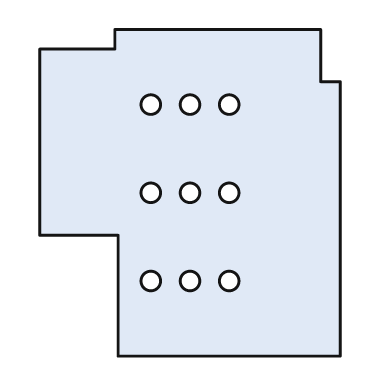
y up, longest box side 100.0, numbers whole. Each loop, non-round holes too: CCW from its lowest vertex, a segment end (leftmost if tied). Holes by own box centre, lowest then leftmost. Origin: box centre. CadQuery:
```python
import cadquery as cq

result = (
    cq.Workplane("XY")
    .moveTo(-22.0, -50.0)
    .lineTo(46.0, -50.0)
    .lineTo(46.0, 34.0)
    .lineTo(40.0, 34.0)
    .lineTo(40.0, 50.0)
    .lineTo(-23.0, 50.0)
    .lineTo(-23.0, 44.0)
    .lineTo(-46.0, 44.0)
    .lineTo(-46.0, -13.0)
    .lineTo(-22.0, -13.0)
    .close()
    .moveTo(-12.0, -27.0)
    .circle(3.0)
    .moveTo(0.0, -27.0)
    .circle(3.0)
    .moveTo(12.0, -27.0)
    .circle(3.0)
    .moveTo(-12.0, 0.0)
    .circle(3.0)
    .moveTo(0.0, 0.0)
    .circle(3.0)
    .moveTo(12.0, 0.0)
    .circle(3.0)
    .moveTo(-12.0, 27.0)
    .circle(3.0)
    .moveTo(0.0, 27.0)
    .circle(3.0)
    .moveTo(12.0, 27.0)
    .circle(3.0)
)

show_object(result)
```